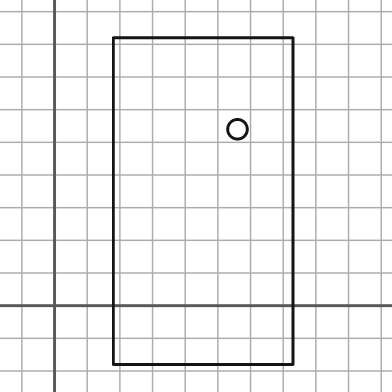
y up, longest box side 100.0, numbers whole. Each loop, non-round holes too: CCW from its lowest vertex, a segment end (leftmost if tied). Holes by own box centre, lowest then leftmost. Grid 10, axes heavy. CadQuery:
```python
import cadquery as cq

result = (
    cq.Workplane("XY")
    .moveTo(18.0, -18.0)
    .lineTo(73.0, -18.0)
    .lineTo(73.0, 82.0)
    .lineTo(18.0, 82.0)
    .close()
    .moveTo(56.0, 54.0)
    .circle(3.0)
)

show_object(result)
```